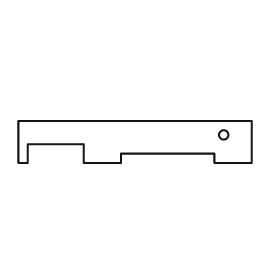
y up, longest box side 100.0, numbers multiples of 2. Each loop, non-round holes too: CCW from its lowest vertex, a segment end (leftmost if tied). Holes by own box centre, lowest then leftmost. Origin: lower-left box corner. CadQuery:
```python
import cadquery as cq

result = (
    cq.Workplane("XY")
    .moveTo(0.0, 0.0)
    .lineTo(4.0, 0.0)
    .lineTo(4.0, 8.0)
    .lineTo(28.0, 8.0)
    .lineTo(28.0, 0.0)
    .lineTo(44.0, 0.0)
    .lineTo(44.0, 4.0)
    .lineTo(84.0, 4.0)
    .lineTo(84.0, 0.0)
    .lineTo(100.0, 0.0)
    .lineTo(100.0, 18.0)
    .lineTo(0.0, 18.0)
    .close()
    .moveTo(88.0, 12.0)
    .circle(2.0)
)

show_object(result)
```